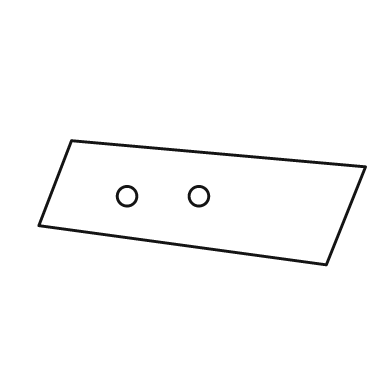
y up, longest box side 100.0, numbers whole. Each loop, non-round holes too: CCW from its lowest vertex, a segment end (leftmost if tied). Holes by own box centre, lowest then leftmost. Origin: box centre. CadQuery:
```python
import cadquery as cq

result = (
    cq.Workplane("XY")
    .moveTo(38.0, -19.0)
    .lineTo(50.0, 11.0)
    .lineTo(-40.0, 19.0)
    .lineTo(-50.0, -7.0)
    .close()
    .moveTo(-23.0, 2.0)
    .circle(3.0)
    .moveTo(-1.0, 2.0)
    .circle(3.0)
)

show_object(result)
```